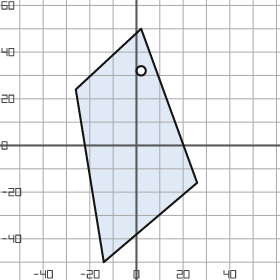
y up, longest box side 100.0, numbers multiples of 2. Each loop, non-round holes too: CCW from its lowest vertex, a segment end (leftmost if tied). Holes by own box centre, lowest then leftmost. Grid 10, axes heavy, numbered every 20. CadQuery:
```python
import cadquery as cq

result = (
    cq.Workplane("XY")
    .moveTo(-14.0, -50.0)
    .lineTo(26.0, -16.0)
    .lineTo(2.0, 50.0)
    .lineTo(-26.0, 24.0)
    .close()
    .moveTo(2.0, 32.0)
    .circle(2.0)
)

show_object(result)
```